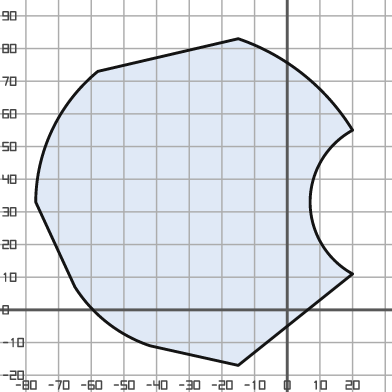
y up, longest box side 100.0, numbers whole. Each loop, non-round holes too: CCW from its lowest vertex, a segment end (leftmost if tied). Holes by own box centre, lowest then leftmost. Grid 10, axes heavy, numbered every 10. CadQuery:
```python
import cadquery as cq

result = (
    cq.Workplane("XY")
    .moveTo(-15.0, -17.0)
    .lineTo(20.0, 11.0)
    .threePointArc((7.0, 33.0), (20.0, 55.0))
    .threePointArc((5.0, 72.0), (-15.0, 83.0))
    .lineTo(-58.0, 73.0)
    .threePointArc((-72.0, 55.0), (-77.0, 33.0))
    .lineTo(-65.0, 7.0)
    .threePointArc((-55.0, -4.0), (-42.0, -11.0))
    .close()
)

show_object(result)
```